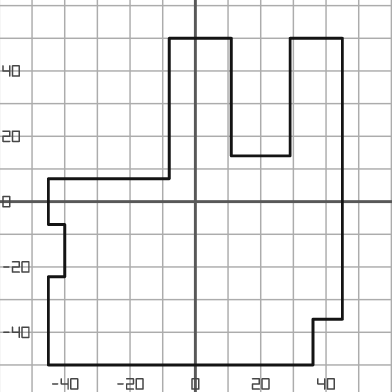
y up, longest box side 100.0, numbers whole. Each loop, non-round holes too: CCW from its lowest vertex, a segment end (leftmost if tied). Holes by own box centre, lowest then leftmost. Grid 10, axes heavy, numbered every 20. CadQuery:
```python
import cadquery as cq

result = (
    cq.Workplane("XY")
    .moveTo(-45.0, -50.0)
    .lineTo(36.0, -50.0)
    .lineTo(36.0, -36.0)
    .lineTo(45.0, -36.0)
    .lineTo(45.0, 50.0)
    .lineTo(29.0, 50.0)
    .lineTo(29.0, 14.0)
    .lineTo(11.0, 14.0)
    .lineTo(11.0, 50.0)
    .lineTo(-8.0, 50.0)
    .lineTo(-8.0, 7.0)
    .lineTo(-45.0, 7.0)
    .lineTo(-45.0, -7.0)
    .lineTo(-40.0, -7.0)
    .lineTo(-40.0, -23.0)
    .lineTo(-45.0, -23.0)
    .close()
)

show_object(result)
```